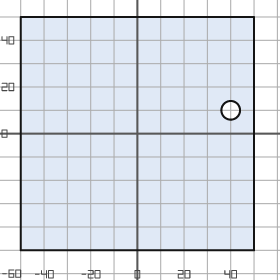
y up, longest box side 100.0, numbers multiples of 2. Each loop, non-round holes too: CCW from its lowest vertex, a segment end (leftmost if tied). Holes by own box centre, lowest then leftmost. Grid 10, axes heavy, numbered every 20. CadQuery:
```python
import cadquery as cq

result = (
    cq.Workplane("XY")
    .moveTo(-50.0, -50.0)
    .lineTo(50.0, -50.0)
    .lineTo(50.0, 50.0)
    .lineTo(-50.0, 50.0)
    .close()
    .moveTo(40.0, 10.0)
    .circle(4.0)
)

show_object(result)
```